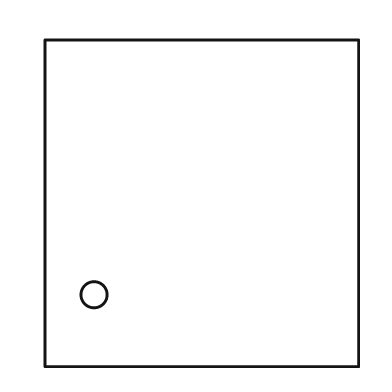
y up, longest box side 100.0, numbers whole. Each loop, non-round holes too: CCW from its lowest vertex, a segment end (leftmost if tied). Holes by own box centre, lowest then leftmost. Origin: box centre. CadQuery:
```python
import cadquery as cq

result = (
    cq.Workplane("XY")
    .moveTo(-48.0, -50.0)
    .lineTo(48.0, -50.0)
    .lineTo(48.0, 50.0)
    .lineTo(-48.0, 50.0)
    .close()
    .moveTo(-33.0, -28.0)
    .circle(4.0)
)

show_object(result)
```